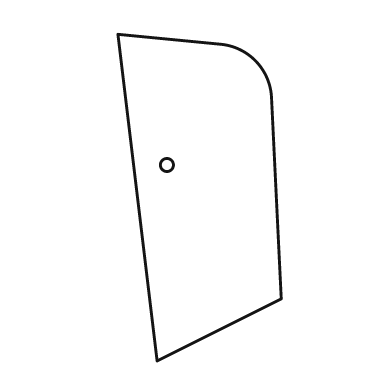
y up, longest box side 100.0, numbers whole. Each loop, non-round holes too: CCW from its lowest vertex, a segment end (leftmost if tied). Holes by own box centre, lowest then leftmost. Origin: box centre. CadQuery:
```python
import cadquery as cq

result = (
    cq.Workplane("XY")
    .moveTo(-13.0, -50.0)
    .lineTo(25.0, -31.0)
    .lineTo(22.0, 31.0)
    .threePointArc((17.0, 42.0), (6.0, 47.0))
    .lineTo(-25.0, 50.0)
    .close()
    .moveTo(-10.0, 10.0)
    .circle(2.0)
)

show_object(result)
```